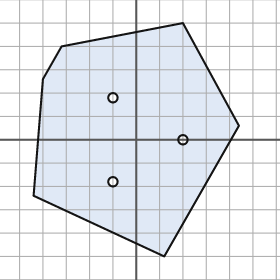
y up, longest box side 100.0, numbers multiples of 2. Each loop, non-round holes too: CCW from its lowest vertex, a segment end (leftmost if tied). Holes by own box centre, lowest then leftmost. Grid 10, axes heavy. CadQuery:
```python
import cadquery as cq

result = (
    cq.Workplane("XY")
    .moveTo(12.0, -50.0)
    .lineTo(44.0, 6.0)
    .lineTo(20.0, 50.0)
    .lineTo(-32.0, 40.0)
    .lineTo(-40.0, 26.0)
    .lineTo(-44.0, -24.0)
    .close()
    .moveTo(-10.0, -18.0)
    .circle(2.0)
    .moveTo(20.0, 0.0)
    .circle(2.0)
    .moveTo(-10.0, 18.0)
    .circle(2.0)
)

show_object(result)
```